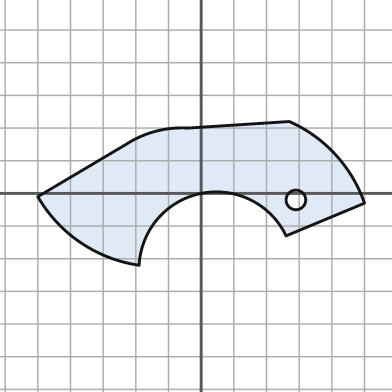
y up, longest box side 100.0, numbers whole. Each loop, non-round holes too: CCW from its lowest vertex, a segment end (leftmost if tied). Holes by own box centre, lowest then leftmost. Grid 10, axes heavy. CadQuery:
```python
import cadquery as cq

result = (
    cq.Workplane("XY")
    .moveTo(-19.0, -22.0)
    .threePointArc((0.0, 0.0), (26.0, -13.0))
    .lineTo(50.0, -3.0)
    .threePointArc((41.0, 12.0), (27.0, 22.0))
    .lineTo(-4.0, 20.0)
    .threePointArc((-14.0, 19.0), (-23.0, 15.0))
    .lineTo(-50.0, -1.0)
    .threePointArc((-37.0, -15.0), (-19.0, -22.0))
    .close()
    .moveTo(29.0, -2.0)
    .circle(3.0)
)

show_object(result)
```